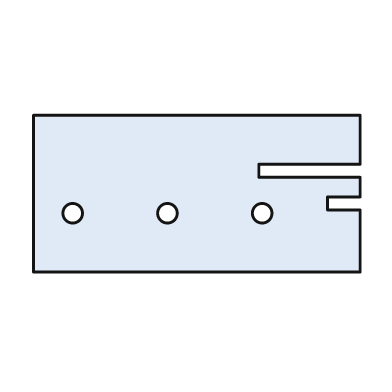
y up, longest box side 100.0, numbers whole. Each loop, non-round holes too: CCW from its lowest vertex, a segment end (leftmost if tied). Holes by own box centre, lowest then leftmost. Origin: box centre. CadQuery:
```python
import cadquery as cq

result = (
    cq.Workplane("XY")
    .moveTo(-50.0, -24.0)
    .lineTo(50.0, -24.0)
    .lineTo(50.0, -5.0)
    .lineTo(40.0, -5.0)
    .lineTo(40.0, -1.0)
    .lineTo(50.0, -1.0)
    .lineTo(50.0, 5.0)
    .lineTo(19.0, 5.0)
    .lineTo(19.0, 9.0)
    .lineTo(50.0, 9.0)
    .lineTo(50.0, 24.0)
    .lineTo(-50.0, 24.0)
    .close()
    .moveTo(-38.0, -6.0)
    .circle(3.0)
    .moveTo(-9.0, -6.0)
    .circle(3.0)
    .moveTo(20.0, -6.0)
    .circle(3.0)
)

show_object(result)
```